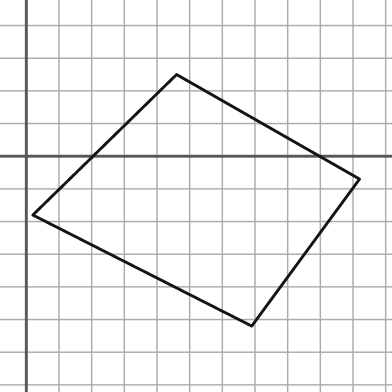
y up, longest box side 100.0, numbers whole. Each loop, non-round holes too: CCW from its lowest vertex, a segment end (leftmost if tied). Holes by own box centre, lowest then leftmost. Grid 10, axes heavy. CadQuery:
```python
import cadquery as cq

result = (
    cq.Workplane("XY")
    .moveTo(69.0, -52.0)
    .lineTo(102.0, -7.0)
    .lineTo(46.0, 25.0)
    .lineTo(2.0, -18.0)
    .close()
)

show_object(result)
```